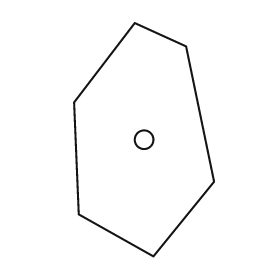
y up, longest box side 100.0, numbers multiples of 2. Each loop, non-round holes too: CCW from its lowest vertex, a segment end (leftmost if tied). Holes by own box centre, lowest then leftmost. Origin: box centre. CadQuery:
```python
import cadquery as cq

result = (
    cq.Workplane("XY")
    .moveTo(4.0, -50.0)
    .lineTo(30.0, -18.0)
    .lineTo(18.0, 40.0)
    .lineTo(-4.0, 50.0)
    .lineTo(-30.0, 16.0)
    .lineTo(-28.0, -32.0)
    .close()
    .moveTo(0.0, 0.0)
    .circle(4.0)
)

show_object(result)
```